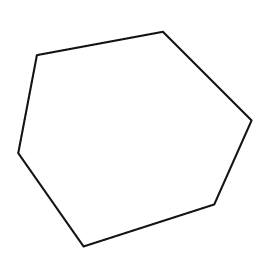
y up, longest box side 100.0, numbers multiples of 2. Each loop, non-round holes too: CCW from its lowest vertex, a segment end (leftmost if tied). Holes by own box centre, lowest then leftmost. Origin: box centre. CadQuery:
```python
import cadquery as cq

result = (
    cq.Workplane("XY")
    .moveTo(-22.0, -46.0)
    .lineTo(34.0, -28.0)
    .lineTo(50.0, 8.0)
    .lineTo(12.0, 46.0)
    .lineTo(-42.0, 36.0)
    .lineTo(-50.0, -6.0)
    .close()
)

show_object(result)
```